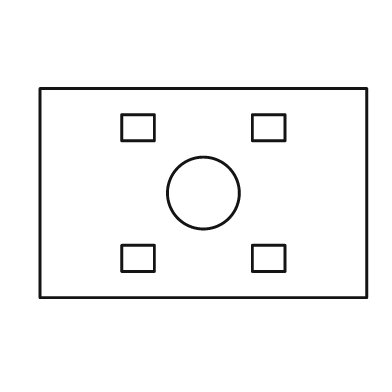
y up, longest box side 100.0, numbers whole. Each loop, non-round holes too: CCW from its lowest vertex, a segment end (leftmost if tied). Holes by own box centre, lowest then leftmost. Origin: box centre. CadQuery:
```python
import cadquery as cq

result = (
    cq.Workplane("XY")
    .moveTo(-50.0, -32.0)
    .lineTo(50.0, -32.0)
    .lineTo(50.0, 32.0)
    .lineTo(-50.0, 32.0)
    .close()
    .moveTo(-25.0, -24.0)
    .lineTo(-15.0, -24.0)
    .lineTo(-15.0, -16.0)
    .lineTo(-25.0, -16.0)
    .close()
    .moveTo(15.0, -24.0)
    .lineTo(25.0, -24.0)
    .lineTo(25.0, -16.0)
    .lineTo(15.0, -16.0)
    .close()
    .moveTo(0.0, 0.0)
    .circle(11.0)
    .moveTo(-25.0, 16.0)
    .lineTo(-15.0, 16.0)
    .lineTo(-15.0, 24.0)
    .lineTo(-25.0, 24.0)
    .close()
    .moveTo(15.0, 16.0)
    .lineTo(25.0, 16.0)
    .lineTo(25.0, 24.0)
    .lineTo(15.0, 24.0)
    .close()
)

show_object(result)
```